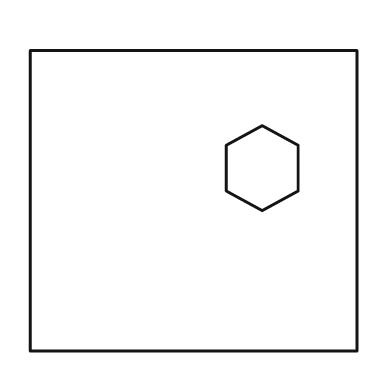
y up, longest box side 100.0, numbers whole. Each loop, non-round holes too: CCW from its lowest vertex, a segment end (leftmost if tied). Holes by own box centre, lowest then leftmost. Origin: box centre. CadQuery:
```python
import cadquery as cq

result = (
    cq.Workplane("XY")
    .moveTo(-50.0, -46.0)
    .lineTo(50.0, -46.0)
    .lineTo(50.0, 46.0)
    .lineTo(-50.0, 46.0)
    .close()
    .moveTo(21.0, -3.0)
    .lineTo(32.0, 3.0)
    .lineTo(32.0, 17.0)
    .lineTo(21.0, 23.0)
    .lineTo(10.0, 17.0)
    .lineTo(10.0, 3.0)
    .close()
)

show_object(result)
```